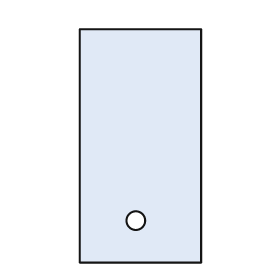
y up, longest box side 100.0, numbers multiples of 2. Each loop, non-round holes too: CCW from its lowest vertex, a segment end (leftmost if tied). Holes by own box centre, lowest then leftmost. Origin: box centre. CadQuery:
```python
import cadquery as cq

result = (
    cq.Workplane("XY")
    .moveTo(-26.0, -50.0)
    .lineTo(26.0, -50.0)
    .lineTo(26.0, 50.0)
    .lineTo(-26.0, 50.0)
    .close()
    .moveTo(-2.0, -32.0)
    .circle(4.0)
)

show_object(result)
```